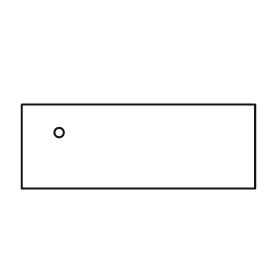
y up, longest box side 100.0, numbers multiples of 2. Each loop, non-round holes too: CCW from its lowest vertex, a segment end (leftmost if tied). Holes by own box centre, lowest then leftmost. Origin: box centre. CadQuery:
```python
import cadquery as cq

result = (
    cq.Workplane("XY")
    .moveTo(-50.0, -18.0)
    .lineTo(50.0, -18.0)
    .lineTo(50.0, 18.0)
    .lineTo(-50.0, 18.0)
    .close()
    .moveTo(-34.0, 6.0)
    .circle(2.0)
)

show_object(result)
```